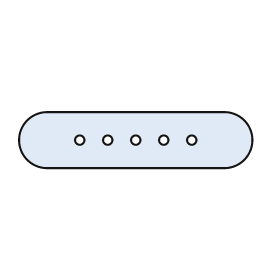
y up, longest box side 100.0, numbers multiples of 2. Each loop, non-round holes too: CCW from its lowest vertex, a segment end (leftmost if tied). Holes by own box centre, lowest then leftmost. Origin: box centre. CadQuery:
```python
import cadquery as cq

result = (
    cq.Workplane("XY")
    .moveTo(-38.0, -12.0)
    .lineTo(38.0, -12.0)
    .threePointArc((50.0, 0.0), (38.0, 12.0))
    .lineTo(-38.0, 12.0)
    .threePointArc((-50.0, 0.0), (-38.0, -12.0))
    .close()
    .moveTo(-24.0, 0.0)
    .circle(2.0)
    .moveTo(-12.0, 0.0)
    .circle(2.0)
    .moveTo(0.0, 0.0)
    .circle(2.0)
    .moveTo(12.0, 0.0)
    .circle(2.0)
    .moveTo(24.0, 0.0)
    .circle(2.0)
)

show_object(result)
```